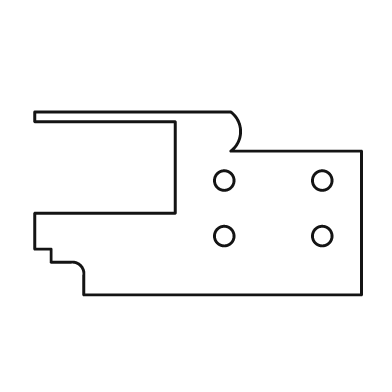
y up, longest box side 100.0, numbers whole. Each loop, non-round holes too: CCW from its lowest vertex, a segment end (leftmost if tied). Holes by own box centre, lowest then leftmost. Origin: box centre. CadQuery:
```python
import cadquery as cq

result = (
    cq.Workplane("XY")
    .moveTo(-35.0, -28.0)
    .lineTo(50.0, -28.0)
    .lineTo(50.0, 16.0)
    .lineTo(10.0, 16.0)
    .threePointArc((13.0, 22.0), (10.0, 28.0))
    .lineTo(-50.0, 28.0)
    .lineTo(-50.0, 25.0)
    .lineTo(-7.0, 25.0)
    .lineTo(-7.0, -3.0)
    .lineTo(-50.0, -3.0)
    .lineTo(-50.0, -14.0)
    .lineTo(-45.0, -14.0)
    .lineTo(-45.0, -18.0)
    .lineTo(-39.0, -18.0)
    .threePointArc((-36.0, -19.0), (-35.0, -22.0))
    .close()
    .moveTo(8.0, -10.0)
    .circle(3.0)
    .moveTo(38.0, -10.0)
    .circle(3.0)
    .moveTo(8.0, 7.0)
    .circle(3.0)
    .moveTo(38.0, 7.0)
    .circle(3.0)
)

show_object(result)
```